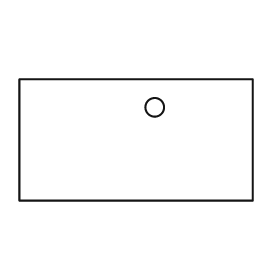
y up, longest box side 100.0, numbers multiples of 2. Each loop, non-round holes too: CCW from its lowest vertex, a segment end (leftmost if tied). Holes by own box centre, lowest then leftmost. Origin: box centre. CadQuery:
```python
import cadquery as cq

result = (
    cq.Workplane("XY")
    .moveTo(-50.0, -26.0)
    .lineTo(50.0, -26.0)
    .lineTo(50.0, 26.0)
    .lineTo(-50.0, 26.0)
    .close()
    .moveTo(8.0, 14.0)
    .circle(4.0)
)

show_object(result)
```